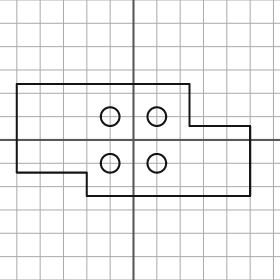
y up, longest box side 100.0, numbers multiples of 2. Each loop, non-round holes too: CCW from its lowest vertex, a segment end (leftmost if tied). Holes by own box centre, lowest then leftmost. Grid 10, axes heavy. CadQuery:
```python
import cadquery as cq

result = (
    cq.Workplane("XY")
    .moveTo(-20.0, -24.0)
    .lineTo(50.0, -24.0)
    .lineTo(50.0, 6.0)
    .lineTo(24.0, 6.0)
    .lineTo(24.0, 24.0)
    .lineTo(-50.0, 24.0)
    .lineTo(-50.0, -14.0)
    .lineTo(-20.0, -14.0)
    .close()
    .moveTo(-10.0, -10.0)
    .circle(4.0)
    .moveTo(10.0, -10.0)
    .circle(4.0)
    .moveTo(-10.0, 10.0)
    .circle(4.0)
    .moveTo(10.0, 10.0)
    .circle(4.0)
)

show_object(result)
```